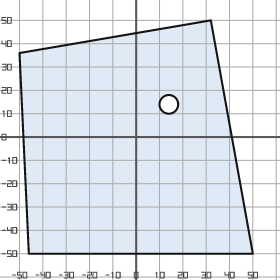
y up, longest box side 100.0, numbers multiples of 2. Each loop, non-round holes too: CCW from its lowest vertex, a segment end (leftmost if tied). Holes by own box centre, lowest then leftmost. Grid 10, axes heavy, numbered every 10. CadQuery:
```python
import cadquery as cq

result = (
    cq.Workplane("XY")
    .moveTo(-46.0, -50.0)
    .lineTo(50.0, -50.0)
    .lineTo(32.0, 50.0)
    .lineTo(-50.0, 36.0)
    .close()
    .moveTo(14.0, 14.0)
    .circle(4.0)
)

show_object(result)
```